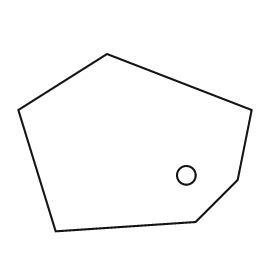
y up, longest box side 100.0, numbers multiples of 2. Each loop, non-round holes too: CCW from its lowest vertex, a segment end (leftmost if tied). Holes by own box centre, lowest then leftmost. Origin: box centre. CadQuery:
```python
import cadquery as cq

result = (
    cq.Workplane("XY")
    .moveTo(-34.0, -38.0)
    .lineTo(26.0, -34.0)
    .lineTo(44.0, -16.0)
    .lineTo(50.0, 14.0)
    .lineTo(-12.0, 38.0)
    .lineTo(-50.0, 14.0)
    .close()
    .moveTo(22.0, -14.0)
    .circle(4.0)
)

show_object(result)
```